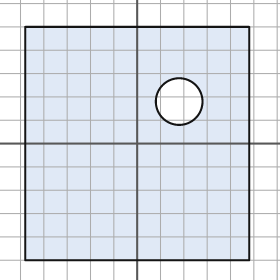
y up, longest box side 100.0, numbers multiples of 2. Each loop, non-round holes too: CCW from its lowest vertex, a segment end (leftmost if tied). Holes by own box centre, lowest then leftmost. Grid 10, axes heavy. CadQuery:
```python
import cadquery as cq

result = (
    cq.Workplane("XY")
    .moveTo(-48.0, -50.0)
    .lineTo(48.0, -50.0)
    .lineTo(48.0, 50.0)
    .lineTo(-48.0, 50.0)
    .close()
    .moveTo(18.0, 18.0)
    .circle(10.0)
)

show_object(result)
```